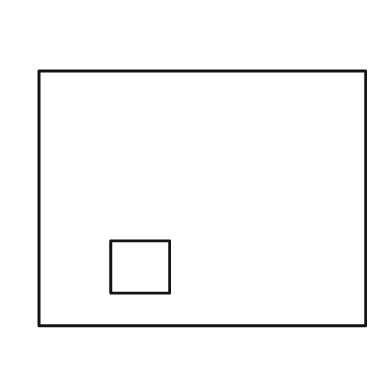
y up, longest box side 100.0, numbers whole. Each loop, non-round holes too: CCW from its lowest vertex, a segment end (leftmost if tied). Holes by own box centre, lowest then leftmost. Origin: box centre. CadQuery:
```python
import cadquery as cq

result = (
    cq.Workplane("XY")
    .moveTo(-50.0, -39.0)
    .lineTo(50.0, -39.0)
    .lineTo(50.0, 39.0)
    .lineTo(-50.0, 39.0)
    .close()
    .moveTo(-28.0, -29.0)
    .lineTo(-10.0, -29.0)
    .lineTo(-10.0, -13.0)
    .lineTo(-28.0, -13.0)
    .close()
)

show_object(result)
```